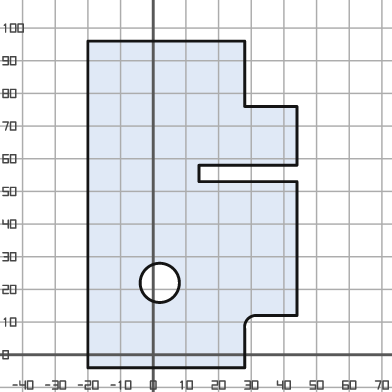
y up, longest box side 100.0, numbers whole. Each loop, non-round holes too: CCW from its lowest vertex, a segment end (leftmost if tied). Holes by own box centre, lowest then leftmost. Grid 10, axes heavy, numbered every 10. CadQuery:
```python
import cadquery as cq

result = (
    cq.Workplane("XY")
    .moveTo(-20.0, -4.0)
    .lineTo(28.0, -4.0)
    .lineTo(28.0, 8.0)
    .threePointArc((29.0, 11.0), (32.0, 12.0))
    .lineTo(44.0, 12.0)
    .lineTo(44.0, 53.0)
    .lineTo(14.0, 53.0)
    .lineTo(14.0, 58.0)
    .lineTo(44.0, 58.0)
    .lineTo(44.0, 76.0)
    .lineTo(28.0, 76.0)
    .lineTo(28.0, 96.0)
    .lineTo(-20.0, 96.0)
    .close()
    .moveTo(2.0, 22.0)
    .circle(6.0)
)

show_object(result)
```